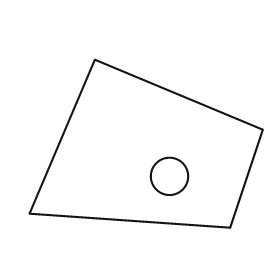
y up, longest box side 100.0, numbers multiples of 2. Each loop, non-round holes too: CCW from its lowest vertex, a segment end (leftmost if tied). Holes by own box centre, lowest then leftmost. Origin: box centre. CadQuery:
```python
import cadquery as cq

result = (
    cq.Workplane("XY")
    .moveTo(36.0, -36.0)
    .lineTo(50.0, 6.0)
    .lineTo(-22.0, 36.0)
    .lineTo(-50.0, -30.0)
    .close()
    .moveTo(10.0, -14.0)
    .circle(8.0)
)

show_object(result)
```